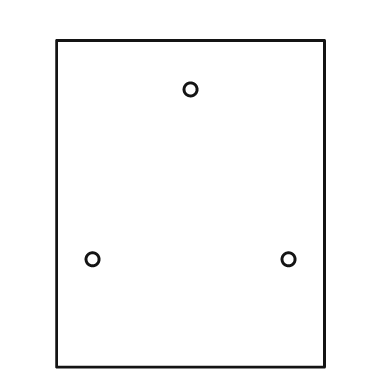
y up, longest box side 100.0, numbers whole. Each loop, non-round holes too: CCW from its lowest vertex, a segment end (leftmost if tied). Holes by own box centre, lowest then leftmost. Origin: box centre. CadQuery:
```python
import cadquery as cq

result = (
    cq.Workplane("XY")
    .moveTo(-41.0, -50.0)
    .lineTo(41.0, -50.0)
    .lineTo(41.0, 50.0)
    .lineTo(-41.0, 50.0)
    .close()
    .moveTo(-30.0, -17.0)
    .circle(2.0)
    .moveTo(30.0, -17.0)
    .circle(2.0)
    .moveTo(0.0, 35.0)
    .circle(2.0)
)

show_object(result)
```